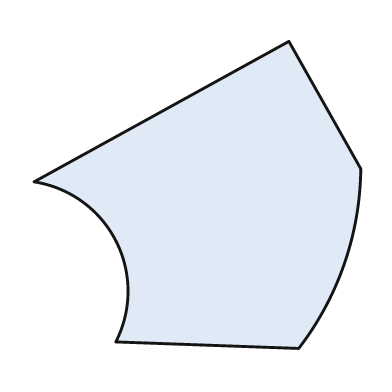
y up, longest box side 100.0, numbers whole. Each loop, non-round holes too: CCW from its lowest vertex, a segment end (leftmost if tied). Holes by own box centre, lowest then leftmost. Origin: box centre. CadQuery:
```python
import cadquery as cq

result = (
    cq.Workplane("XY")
    .moveTo(31.0, -47.0)
    .threePointArc((45.0, -21.0), (50.0, 8.0))
    .lineTo(28.0, 47.0)
    .lineTo(-50.0, 4.0)
    .threePointArc((-25.0, -14.0), (-25.0, -45.0))
    .close()
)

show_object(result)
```